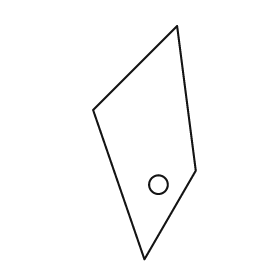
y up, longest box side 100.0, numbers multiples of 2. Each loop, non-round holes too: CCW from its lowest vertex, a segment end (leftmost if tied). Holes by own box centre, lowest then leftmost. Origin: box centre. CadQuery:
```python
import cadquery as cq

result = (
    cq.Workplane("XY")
    .moveTo(0.0, -50.0)
    .lineTo(22.0, -12.0)
    .lineTo(14.0, 50.0)
    .lineTo(-22.0, 14.0)
    .close()
    .moveTo(6.0, -18.0)
    .circle(4.0)
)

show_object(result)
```